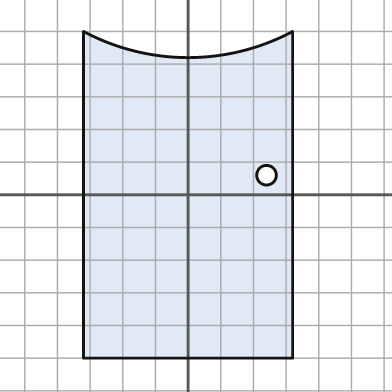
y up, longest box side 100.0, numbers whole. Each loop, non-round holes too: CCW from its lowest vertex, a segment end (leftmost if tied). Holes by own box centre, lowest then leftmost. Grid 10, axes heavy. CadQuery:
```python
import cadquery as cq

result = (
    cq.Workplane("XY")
    .moveTo(-32.0, -50.0)
    .lineTo(32.0, -50.0)
    .lineTo(32.0, 50.0)
    .threePointArc((0.0, 42.0), (-32.0, 50.0))
    .close()
    .moveTo(24.0, 6.0)
    .circle(3.0)
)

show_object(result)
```